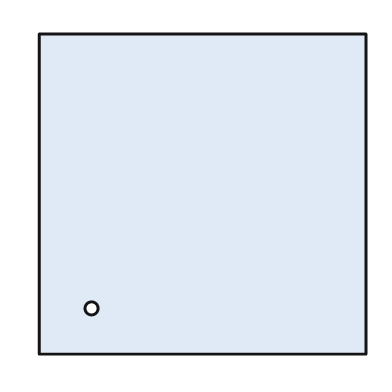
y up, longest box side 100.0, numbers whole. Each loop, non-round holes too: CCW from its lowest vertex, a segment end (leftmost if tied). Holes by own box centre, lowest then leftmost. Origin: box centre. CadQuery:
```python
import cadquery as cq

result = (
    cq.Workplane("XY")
    .moveTo(-50.0, -49.0)
    .lineTo(50.0, -49.0)
    .lineTo(50.0, 49.0)
    .lineTo(-50.0, 49.0)
    .close()
    .moveTo(-34.0, -35.0)
    .circle(2.0)
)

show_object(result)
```